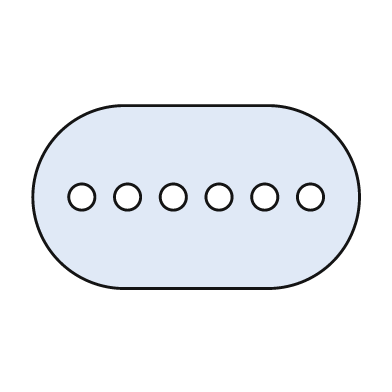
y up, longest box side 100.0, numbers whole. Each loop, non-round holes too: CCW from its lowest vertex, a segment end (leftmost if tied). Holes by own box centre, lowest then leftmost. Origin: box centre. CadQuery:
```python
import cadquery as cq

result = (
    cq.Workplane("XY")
    .moveTo(-22.0, -28.0)
    .lineTo(22.0, -28.0)
    .threePointArc((50.0, 0.0), (22.0, 28.0))
    .lineTo(-22.0, 28.0)
    .threePointArc((-50.0, 0.0), (-22.0, -28.0))
    .close()
    .moveTo(-35.0, 0.0)
    .circle(4.0)
    .moveTo(-21.0, 0.0)
    .circle(4.0)
    .moveTo(-7.0, 0.0)
    .circle(4.0)
    .moveTo(7.0, 0.0)
    .circle(4.0)
    .moveTo(21.0, 0.0)
    .circle(4.0)
    .moveTo(35.0, 0.0)
    .circle(4.0)
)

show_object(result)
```